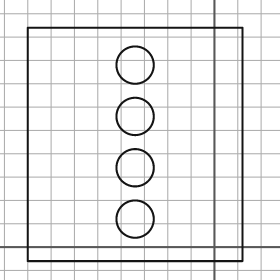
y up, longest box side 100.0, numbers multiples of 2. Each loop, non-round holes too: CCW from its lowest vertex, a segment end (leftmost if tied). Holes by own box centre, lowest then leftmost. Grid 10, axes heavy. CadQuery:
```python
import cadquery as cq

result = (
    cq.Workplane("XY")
    .moveTo(-80.0, -6.0)
    .lineTo(12.0, -6.0)
    .lineTo(12.0, 94.0)
    .lineTo(-80.0, 94.0)
    .close()
    .moveTo(-34.0, 12.0)
    .circle(8.0)
    .moveTo(-34.0, 34.0)
    .circle(8.0)
    .moveTo(-34.0, 56.0)
    .circle(8.0)
    .moveTo(-34.0, 78.0)
    .circle(8.0)
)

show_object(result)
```